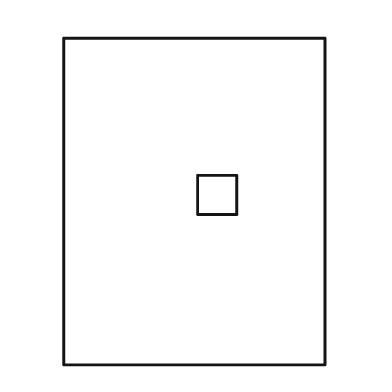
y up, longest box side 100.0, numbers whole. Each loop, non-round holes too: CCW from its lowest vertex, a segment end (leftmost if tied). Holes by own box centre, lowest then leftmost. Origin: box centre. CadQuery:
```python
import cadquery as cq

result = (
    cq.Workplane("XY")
    .moveTo(-40.0, -50.0)
    .lineTo(40.0, -50.0)
    .lineTo(40.0, 50.0)
    .lineTo(-40.0, 50.0)
    .close()
    .moveTo(1.0, -4.0)
    .lineTo(13.0, -4.0)
    .lineTo(13.0, 8.0)
    .lineTo(1.0, 8.0)
    .close()
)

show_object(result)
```